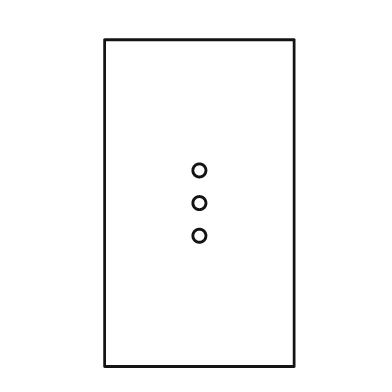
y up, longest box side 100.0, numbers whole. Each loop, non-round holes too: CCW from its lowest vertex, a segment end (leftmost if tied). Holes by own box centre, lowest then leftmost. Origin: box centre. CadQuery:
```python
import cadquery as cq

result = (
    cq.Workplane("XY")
    .moveTo(-29.0, -50.0)
    .lineTo(29.0, -50.0)
    .lineTo(29.0, 50.0)
    .lineTo(-29.0, 50.0)
    .close()
    .moveTo(0.0, -10.0)
    .circle(2.0)
    .moveTo(0.0, 0.0)
    .circle(2.0)
    .moveTo(0.0, 10.0)
    .circle(2.0)
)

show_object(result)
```